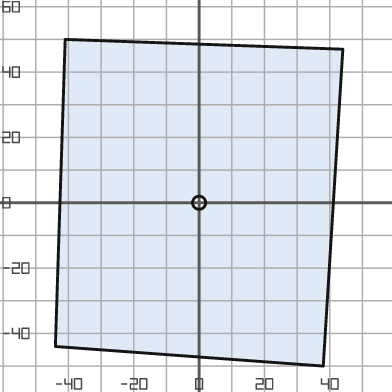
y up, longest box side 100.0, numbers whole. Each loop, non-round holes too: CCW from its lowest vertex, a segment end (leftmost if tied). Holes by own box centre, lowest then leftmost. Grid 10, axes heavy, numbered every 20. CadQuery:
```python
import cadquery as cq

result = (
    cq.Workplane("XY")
    .moveTo(38.0, -50.0)
    .lineTo(44.0, 47.0)
    .lineTo(-41.0, 50.0)
    .lineTo(-44.0, -44.0)
    .close()
    .moveTo(0.0, 0.0)
    .circle(2.0)
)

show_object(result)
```